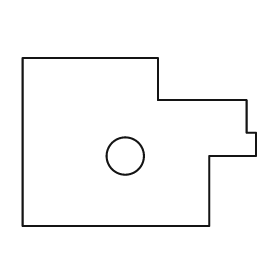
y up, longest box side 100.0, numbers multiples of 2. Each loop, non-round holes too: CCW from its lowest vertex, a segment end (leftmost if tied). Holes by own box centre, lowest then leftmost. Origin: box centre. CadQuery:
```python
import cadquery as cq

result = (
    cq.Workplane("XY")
    .moveTo(-50.0, -36.0)
    .lineTo(30.0, -36.0)
    .lineTo(30.0, -6.0)
    .lineTo(50.0, -6.0)
    .lineTo(50.0, 4.0)
    .lineTo(46.0, 4.0)
    .lineTo(46.0, 18.0)
    .lineTo(8.0, 18.0)
    .lineTo(8.0, 36.0)
    .lineTo(-50.0, 36.0)
    .close()
    .moveTo(-6.0, -6.0)
    .circle(8.0)
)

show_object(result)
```